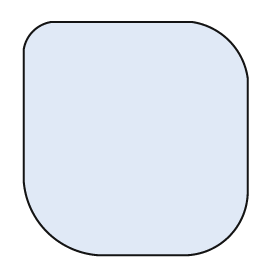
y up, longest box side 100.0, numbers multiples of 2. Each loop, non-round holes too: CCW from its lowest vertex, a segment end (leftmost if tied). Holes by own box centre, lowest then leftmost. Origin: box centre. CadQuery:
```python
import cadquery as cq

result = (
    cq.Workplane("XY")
    .moveTo(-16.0, -50.0)
    .lineTo(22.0, -50.0)
    .threePointArc((40.0, -42.0), (48.0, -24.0))
    .lineTo(48.0, 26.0)
    .threePointArc((40.0, 42.0), (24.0, 50.0))
    .lineTo(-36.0, 50.0)
    .threePointArc((-44.0, 46.0), (-48.0, 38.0))
    .lineTo(-48.0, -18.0)
    .threePointArc((-38.0, -40.0), (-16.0, -50.0))
    .close()
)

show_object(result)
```